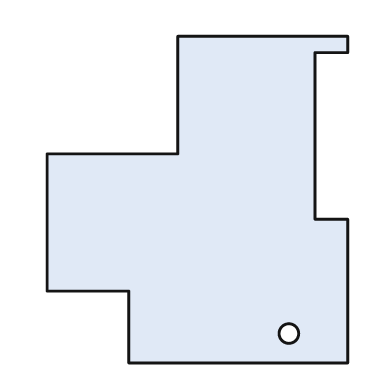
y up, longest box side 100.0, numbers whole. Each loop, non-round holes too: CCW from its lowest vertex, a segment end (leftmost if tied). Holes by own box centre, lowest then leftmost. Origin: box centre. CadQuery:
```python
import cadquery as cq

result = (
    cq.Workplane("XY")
    .moveTo(-21.0, -50.0)
    .lineTo(46.0, -50.0)
    .lineTo(46.0, -6.0)
    .lineTo(36.0, -6.0)
    .lineTo(36.0, 45.0)
    .lineTo(46.0, 45.0)
    .lineTo(46.0, 50.0)
    .lineTo(-6.0, 50.0)
    .lineTo(-6.0, 14.0)
    .lineTo(-46.0, 14.0)
    .lineTo(-46.0, -28.0)
    .lineTo(-21.0, -28.0)
    .close()
    .moveTo(28.0, -41.0)
    .circle(3.0)
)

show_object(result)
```